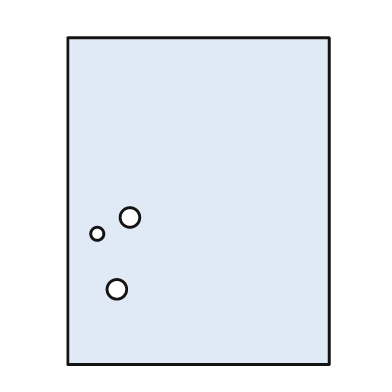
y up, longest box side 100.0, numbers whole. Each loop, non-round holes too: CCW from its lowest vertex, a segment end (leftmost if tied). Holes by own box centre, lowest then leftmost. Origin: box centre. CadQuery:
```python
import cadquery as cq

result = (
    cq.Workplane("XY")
    .moveTo(-40.0, -50.0)
    .lineTo(40.0, -50.0)
    .lineTo(40.0, 50.0)
    .lineTo(-40.0, 50.0)
    .close()
    .moveTo(-25.0, -27.0)
    .circle(3.0)
    .moveTo(-31.0, -10.0)
    .circle(2.0)
    .moveTo(-21.0, -5.0)
    .circle(3.0)
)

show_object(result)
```